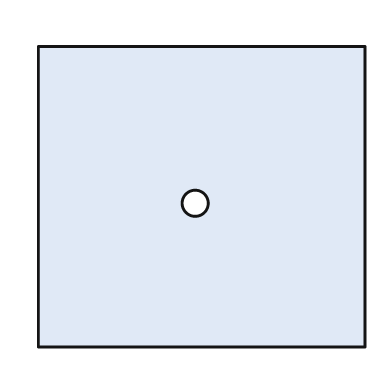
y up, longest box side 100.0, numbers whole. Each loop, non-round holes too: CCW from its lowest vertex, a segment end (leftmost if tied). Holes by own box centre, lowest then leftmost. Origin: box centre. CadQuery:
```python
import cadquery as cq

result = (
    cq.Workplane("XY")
    .moveTo(-50.0, -46.0)
    .lineTo(50.0, -46.0)
    .lineTo(50.0, 46.0)
    .lineTo(-50.0, 46.0)
    .close()
    .moveTo(-2.0, -2.0)
    .circle(4.0)
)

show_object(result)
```